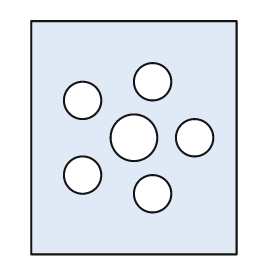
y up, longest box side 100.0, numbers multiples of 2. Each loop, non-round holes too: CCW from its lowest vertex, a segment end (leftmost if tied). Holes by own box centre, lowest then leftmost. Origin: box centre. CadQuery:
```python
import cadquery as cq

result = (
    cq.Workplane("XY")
    .moveTo(-44.0, -50.0)
    .lineTo(44.0, -50.0)
    .lineTo(44.0, 50.0)
    .lineTo(-44.0, 50.0)
    .close()
    .moveTo(8.0, -24.0)
    .circle(8.0)
    .moveTo(-22.0, -16.0)
    .circle(8.0)
    .moveTo(0.0, 0.0)
    .circle(10.0)
    .moveTo(26.0, 0.0)
    .circle(8.0)
    .moveTo(-22.0, 16.0)
    .circle(8.0)
    .moveTo(8.0, 24.0)
    .circle(8.0)
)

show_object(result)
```